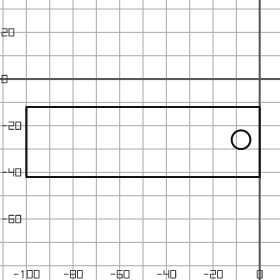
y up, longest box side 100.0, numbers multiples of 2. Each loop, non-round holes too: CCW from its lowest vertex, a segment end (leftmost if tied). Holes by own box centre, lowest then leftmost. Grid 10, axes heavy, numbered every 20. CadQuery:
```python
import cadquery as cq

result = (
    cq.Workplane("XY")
    .moveTo(-100.0, -42.0)
    .lineTo(0.0, -42.0)
    .lineTo(0.0, -12.0)
    .lineTo(-100.0, -12.0)
    .close()
    .moveTo(-8.0, -26.0)
    .circle(4.0)
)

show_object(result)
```